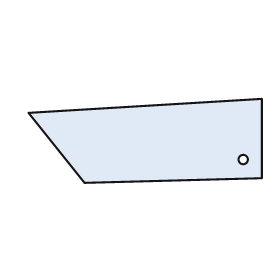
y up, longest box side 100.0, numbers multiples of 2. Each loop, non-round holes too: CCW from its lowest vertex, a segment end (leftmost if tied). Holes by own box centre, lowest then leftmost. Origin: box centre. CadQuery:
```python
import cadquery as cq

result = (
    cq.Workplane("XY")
    .moveTo(-26.0, -18.0)
    .lineTo(50.0, -16.0)
    .lineTo(50.0, 18.0)
    .lineTo(-50.0, 12.0)
    .close()
    .moveTo(42.0, -8.0)
    .circle(2.0)
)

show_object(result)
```